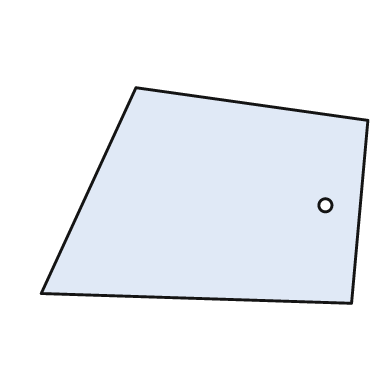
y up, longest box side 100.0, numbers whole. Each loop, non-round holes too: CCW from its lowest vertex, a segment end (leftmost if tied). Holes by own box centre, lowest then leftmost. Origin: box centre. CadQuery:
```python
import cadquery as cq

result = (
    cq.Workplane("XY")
    .moveTo(45.0, -33.0)
    .lineTo(50.0, 23.0)
    .lineTo(-21.0, 33.0)
    .lineTo(-50.0, -30.0)
    .close()
    .moveTo(37.0, -3.0)
    .circle(2.0)
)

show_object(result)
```